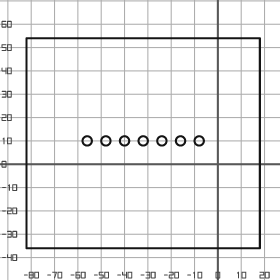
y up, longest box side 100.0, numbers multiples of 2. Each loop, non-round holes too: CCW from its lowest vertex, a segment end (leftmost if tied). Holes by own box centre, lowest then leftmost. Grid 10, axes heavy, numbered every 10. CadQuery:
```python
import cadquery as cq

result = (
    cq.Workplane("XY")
    .moveTo(-82.0, -36.0)
    .lineTo(18.0, -36.0)
    .lineTo(18.0, 54.0)
    .lineTo(-82.0, 54.0)
    .close()
    .moveTo(-56.0, 10.0)
    .circle(2.0)
    .moveTo(-48.0, 10.0)
    .circle(2.0)
    .moveTo(-40.0, 10.0)
    .circle(2.0)
    .moveTo(-32.0, 10.0)
    .circle(2.0)
    .moveTo(-24.0, 10.0)
    .circle(2.0)
    .moveTo(-16.0, 10.0)
    .circle(2.0)
    .moveTo(-8.0, 10.0)
    .circle(2.0)
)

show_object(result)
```